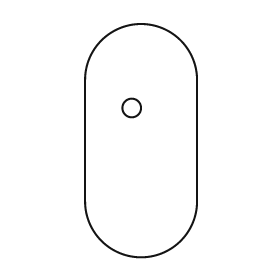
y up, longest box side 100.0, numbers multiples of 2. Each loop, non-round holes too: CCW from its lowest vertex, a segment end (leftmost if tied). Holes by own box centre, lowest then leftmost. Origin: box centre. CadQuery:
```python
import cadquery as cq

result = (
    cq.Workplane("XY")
    .moveTo(-24.0, -26.0)
    .threePointArc((0.0, -50.0), (24.0, -26.0))
    .lineTo(24.0, 26.0)
    .threePointArc((0.0, 50.0), (-24.0, 26.0))
    .close()
    .moveTo(-4.0, 14.0)
    .circle(4.0)
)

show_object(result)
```